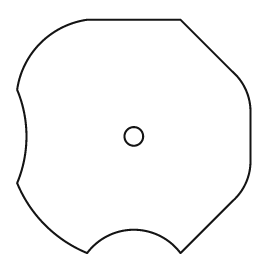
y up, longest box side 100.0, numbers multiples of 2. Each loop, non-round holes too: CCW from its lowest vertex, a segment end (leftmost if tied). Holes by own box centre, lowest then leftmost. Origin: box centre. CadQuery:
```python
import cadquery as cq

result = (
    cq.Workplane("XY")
    .moveTo(-20.0, -50.0)
    .threePointArc((0.0, -40.0), (20.0, -50.0))
    .lineTo(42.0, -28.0)
    .threePointArc((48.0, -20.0), (50.0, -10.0))
    .lineTo(50.0, 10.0)
    .threePointArc((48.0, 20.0), (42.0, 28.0))
    .lineTo(20.0, 50.0)
    .lineTo(-20.0, 50.0)
    .threePointArc((-40.0, 40.0), (-50.0, 20.0))
    .threePointArc((-46.0, 0.0), (-50.0, -20.0))
    .threePointArc((-38.0, -38.0), (-20.0, -50.0))
    .close()
    .moveTo(0.0, 0.0)
    .circle(4.0)
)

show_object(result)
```